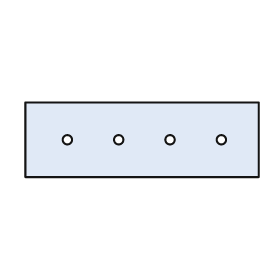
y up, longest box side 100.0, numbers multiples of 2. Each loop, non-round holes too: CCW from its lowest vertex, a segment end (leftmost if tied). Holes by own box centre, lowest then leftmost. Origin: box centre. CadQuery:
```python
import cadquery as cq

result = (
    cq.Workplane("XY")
    .moveTo(-50.0, -16.0)
    .lineTo(50.0, -16.0)
    .lineTo(50.0, 16.0)
    .lineTo(-50.0, 16.0)
    .close()
    .moveTo(-32.0, 0.0)
    .circle(2.0)
    .moveTo(-10.0, 0.0)
    .circle(2.0)
    .moveTo(12.0, 0.0)
    .circle(2.0)
    .moveTo(34.0, 0.0)
    .circle(2.0)
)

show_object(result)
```